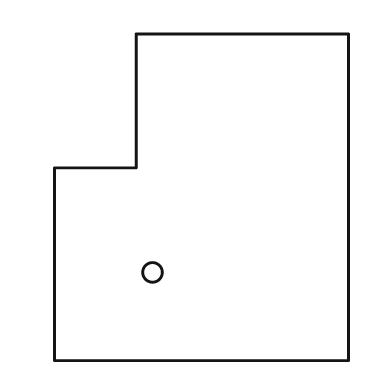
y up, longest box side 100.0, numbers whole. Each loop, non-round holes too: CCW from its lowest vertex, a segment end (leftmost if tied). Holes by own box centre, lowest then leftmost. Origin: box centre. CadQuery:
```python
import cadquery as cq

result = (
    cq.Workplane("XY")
    .moveTo(-45.0, -50.0)
    .lineTo(45.0, -50.0)
    .lineTo(45.0, 50.0)
    .lineTo(-20.0, 50.0)
    .lineTo(-20.0, 9.0)
    .lineTo(-45.0, 9.0)
    .close()
    .moveTo(-15.0, -23.0)
    .circle(3.0)
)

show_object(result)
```